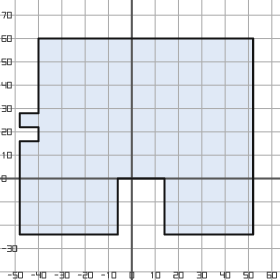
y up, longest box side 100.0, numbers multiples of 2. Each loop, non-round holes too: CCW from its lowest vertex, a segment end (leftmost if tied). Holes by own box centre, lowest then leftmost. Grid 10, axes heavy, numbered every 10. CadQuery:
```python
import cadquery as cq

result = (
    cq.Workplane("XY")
    .moveTo(-48.0, -24.0)
    .lineTo(-6.0, -24.0)
    .lineTo(-6.0, 0.0)
    .lineTo(14.0, 0.0)
    .lineTo(14.0, -24.0)
    .lineTo(52.0, -24.0)
    .lineTo(52.0, 60.0)
    .lineTo(-40.0, 60.0)
    .lineTo(-40.0, 28.0)
    .lineTo(-48.0, 28.0)
    .lineTo(-48.0, 22.0)
    .lineTo(-40.0, 22.0)
    .lineTo(-40.0, 16.0)
    .lineTo(-48.0, 16.0)
    .close()
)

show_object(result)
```